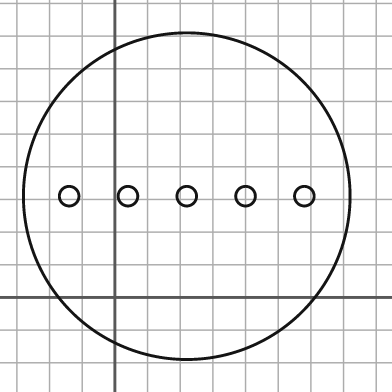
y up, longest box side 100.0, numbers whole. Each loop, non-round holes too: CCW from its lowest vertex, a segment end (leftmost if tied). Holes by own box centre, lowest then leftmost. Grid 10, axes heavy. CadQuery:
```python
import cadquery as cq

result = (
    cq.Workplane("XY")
    .moveTo(22.0, 31.0)
    .circle(50.0)
    .moveTo(-14.0, 31.0)
    .circle(3.0)
    .moveTo(4.0, 31.0)
    .circle(3.0)
    .moveTo(22.0, 31.0)
    .circle(3.0)
    .moveTo(40.0, 31.0)
    .circle(3.0)
    .moveTo(58.0, 31.0)
    .circle(3.0)
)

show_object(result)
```